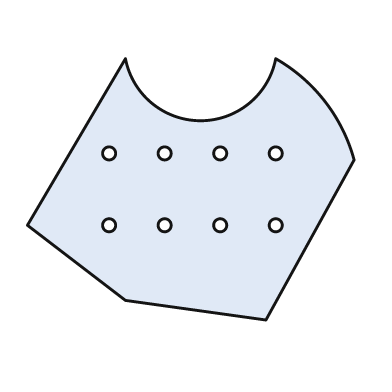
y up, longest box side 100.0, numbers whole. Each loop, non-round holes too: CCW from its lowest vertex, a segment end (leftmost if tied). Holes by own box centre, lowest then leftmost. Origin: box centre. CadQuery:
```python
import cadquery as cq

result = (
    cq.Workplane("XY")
    .moveTo(23.0, -40.0)
    .lineTo(50.0, 9.0)
    .threePointArc((41.0, 27.0), (26.0, 40.0))
    .threePointArc((3.0, 21.0), (-20.0, 40.0))
    .lineTo(-50.0, -11.0)
    .lineTo(-20.0, -34.0)
    .close()
    .moveTo(-25.0, -11.0)
    .circle(2.0)
    .moveTo(-8.0, -11.0)
    .circle(2.0)
    .moveTo(9.0, -11.0)
    .circle(2.0)
    .moveTo(26.0, -11.0)
    .circle(2.0)
    .moveTo(-25.0, 11.0)
    .circle(2.0)
    .moveTo(-8.0, 11.0)
    .circle(2.0)
    .moveTo(9.0, 11.0)
    .circle(2.0)
    .moveTo(26.0, 11.0)
    .circle(2.0)
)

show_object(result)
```